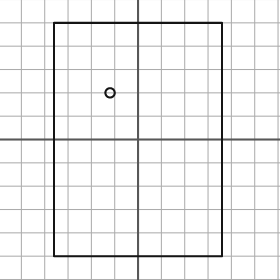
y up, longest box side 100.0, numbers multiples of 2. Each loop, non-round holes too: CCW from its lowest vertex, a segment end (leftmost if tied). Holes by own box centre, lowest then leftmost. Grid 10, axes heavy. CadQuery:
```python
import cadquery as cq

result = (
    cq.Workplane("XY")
    .moveTo(-36.0, -50.0)
    .lineTo(36.0, -50.0)
    .lineTo(36.0, 50.0)
    .lineTo(-36.0, 50.0)
    .close()
    .moveTo(-12.0, 20.0)
    .circle(2.0)
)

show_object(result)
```